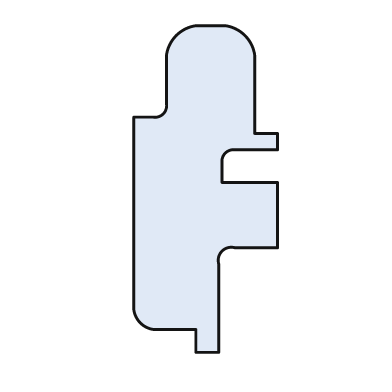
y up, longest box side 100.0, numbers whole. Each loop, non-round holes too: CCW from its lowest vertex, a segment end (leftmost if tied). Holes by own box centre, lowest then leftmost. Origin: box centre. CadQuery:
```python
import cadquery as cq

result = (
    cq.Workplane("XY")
    .moveTo(-3.0, -50.0)
    .lineTo(4.0, -50.0)
    .lineTo(4.0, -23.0)
    .threePointArc((5.0, -19.0), (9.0, -18.0))
    .lineTo(22.0, -18.0)
    .lineTo(22.0, 2.0)
    .lineTo(5.0, 2.0)
    .lineTo(5.0, 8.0)
    .threePointArc((6.0, 11.0), (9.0, 12.0))
    .lineTo(22.0, 12.0)
    .lineTo(22.0, 17.0)
    .lineTo(15.0, 17.0)
    .lineTo(15.0, 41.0)
    .threePointArc((12.0, 47.0), (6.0, 50.0))
    .lineTo(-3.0, 50.0)
    .threePointArc((-9.0, 47.0), (-12.0, 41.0))
    .lineTo(-12.0, 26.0)
    .threePointArc((-13.0, 23.0), (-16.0, 22.0))
    .lineTo(-22.0, 22.0)
    .lineTo(-22.0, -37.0)
    .threePointArc((-20.0, -41.0), (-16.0, -43.0))
    .lineTo(-3.0, -43.0)
    .close()
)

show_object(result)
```